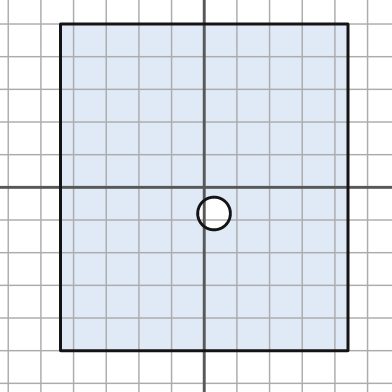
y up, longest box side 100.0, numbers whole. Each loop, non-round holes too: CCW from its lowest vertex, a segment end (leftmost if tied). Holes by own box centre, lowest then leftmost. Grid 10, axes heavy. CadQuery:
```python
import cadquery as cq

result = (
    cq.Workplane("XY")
    .moveTo(-44.0, -50.0)
    .lineTo(44.0, -50.0)
    .lineTo(44.0, 50.0)
    .lineTo(-44.0, 50.0)
    .close()
    .moveTo(3.0, -8.0)
    .circle(5.0)
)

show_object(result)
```